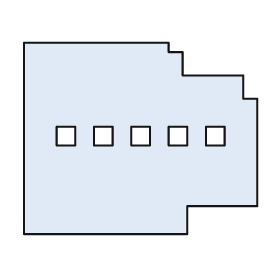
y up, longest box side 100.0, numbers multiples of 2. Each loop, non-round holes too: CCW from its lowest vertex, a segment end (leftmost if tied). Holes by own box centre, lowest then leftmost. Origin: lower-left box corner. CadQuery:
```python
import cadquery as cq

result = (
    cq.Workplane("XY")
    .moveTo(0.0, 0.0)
    .lineTo(70.0, 0.0)
    .lineTo(70.0, 12.0)
    .lineTo(100.0, 12.0)
    .lineTo(100.0, 58.0)
    .lineTo(94.0, 58.0)
    .lineTo(94.0, 68.0)
    .lineTo(68.0, 68.0)
    .lineTo(68.0, 78.0)
    .lineTo(62.0, 78.0)
    .lineTo(62.0, 82.0)
    .lineTo(0.0, 82.0)
    .close()
    .moveTo(14.0, 38.0)
    .lineTo(22.0, 38.0)
    .lineTo(22.0, 46.0)
    .lineTo(14.0, 46.0)
    .close()
    .moveTo(30.0, 38.0)
    .lineTo(38.0, 38.0)
    .lineTo(38.0, 46.0)
    .lineTo(30.0, 46.0)
    .close()
    .moveTo(46.0, 38.0)
    .lineTo(54.0, 38.0)
    .lineTo(54.0, 46.0)
    .lineTo(46.0, 46.0)
    .close()
    .moveTo(62.0, 38.0)
    .lineTo(70.0, 38.0)
    .lineTo(70.0, 46.0)
    .lineTo(62.0, 46.0)
    .close()
    .moveTo(78.0, 38.0)
    .lineTo(86.0, 38.0)
    .lineTo(86.0, 46.0)
    .lineTo(78.0, 46.0)
    .close()
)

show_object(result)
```